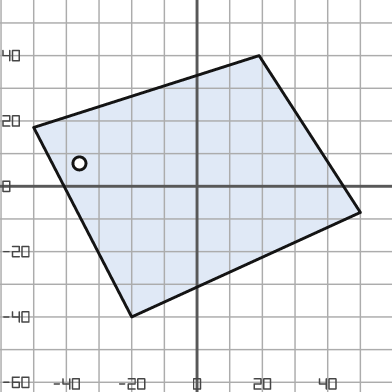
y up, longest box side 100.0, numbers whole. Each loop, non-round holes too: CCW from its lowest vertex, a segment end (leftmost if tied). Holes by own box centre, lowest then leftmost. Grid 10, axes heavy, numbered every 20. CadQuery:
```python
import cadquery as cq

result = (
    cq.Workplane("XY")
    .moveTo(-20.0, -40.0)
    .lineTo(50.0, -8.0)
    .lineTo(19.0, 40.0)
    .lineTo(-50.0, 18.0)
    .close()
    .moveTo(-36.0, 7.0)
    .circle(2.0)
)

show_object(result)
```